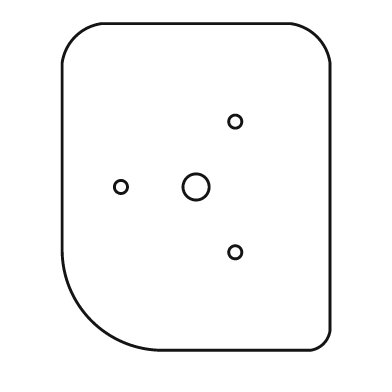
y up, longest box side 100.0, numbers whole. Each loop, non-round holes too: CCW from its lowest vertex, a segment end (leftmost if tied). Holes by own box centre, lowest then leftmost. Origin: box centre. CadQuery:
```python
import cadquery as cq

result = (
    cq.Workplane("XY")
    .moveTo(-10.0, -50.0)
    .lineTo(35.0, -50.0)
    .threePointArc((39.0, -48.0), (41.0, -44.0))
    .lineTo(41.0, 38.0)
    .threePointArc((37.0, 46.0), (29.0, 50.0))
    .lineTo(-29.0, 50.0)
    .threePointArc((-37.0, 46.0), (-41.0, 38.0))
    .lineTo(-41.0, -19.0)
    .threePointArc((-32.0, -41.0), (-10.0, -50.0))
    .close()
    .moveTo(12.0, -20.0)
    .circle(2.0)
    .moveTo(-23.0, 0.0)
    .circle(2.0)
    .moveTo(0.0, 0.0)
    .circle(4.0)
    .moveTo(12.0, 20.0)
    .circle(2.0)
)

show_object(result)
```